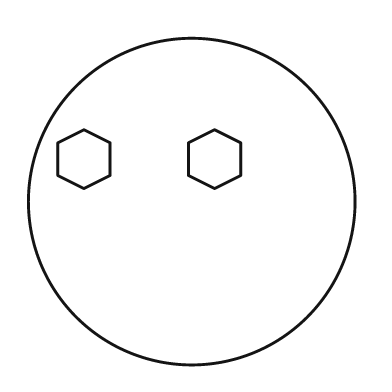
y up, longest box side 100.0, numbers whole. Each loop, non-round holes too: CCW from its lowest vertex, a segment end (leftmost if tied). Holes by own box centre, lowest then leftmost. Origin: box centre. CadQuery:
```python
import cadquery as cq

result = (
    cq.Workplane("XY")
    .moveTo(0.0, 0.0)
    .circle(50.0)
    .moveTo(-33.0, 4.0)
    .lineTo(-25.0, 8.0)
    .lineTo(-25.0, 18.0)
    .lineTo(-33.0, 22.0)
    .lineTo(-41.0, 18.0)
    .lineTo(-41.0, 8.0)
    .close()
    .moveTo(7.0, 4.0)
    .lineTo(15.0, 8.0)
    .lineTo(15.0, 18.0)
    .lineTo(7.0, 22.0)
    .lineTo(-1.0, 18.0)
    .lineTo(-1.0, 8.0)
    .close()
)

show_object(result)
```